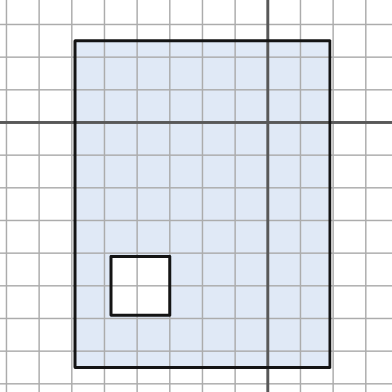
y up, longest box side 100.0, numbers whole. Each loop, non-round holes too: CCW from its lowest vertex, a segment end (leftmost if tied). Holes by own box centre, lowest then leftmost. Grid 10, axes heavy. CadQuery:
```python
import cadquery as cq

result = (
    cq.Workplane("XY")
    .moveTo(-59.0, -75.0)
    .lineTo(19.0, -75.0)
    .lineTo(19.0, 25.0)
    .lineTo(-59.0, 25.0)
    .close()
    .moveTo(-48.0, -59.0)
    .lineTo(-30.0, -59.0)
    .lineTo(-30.0, -41.0)
    .lineTo(-48.0, -41.0)
    .close()
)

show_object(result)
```